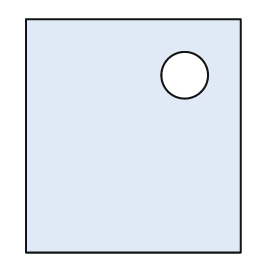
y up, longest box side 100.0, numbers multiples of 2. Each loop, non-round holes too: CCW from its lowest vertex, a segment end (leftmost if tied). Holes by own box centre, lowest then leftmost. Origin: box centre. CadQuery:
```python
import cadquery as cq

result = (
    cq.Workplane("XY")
    .moveTo(-46.0, -50.0)
    .lineTo(46.0, -50.0)
    .lineTo(46.0, 50.0)
    .lineTo(-46.0, 50.0)
    .close()
    .moveTo(22.0, 26.0)
    .circle(10.0)
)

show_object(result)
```